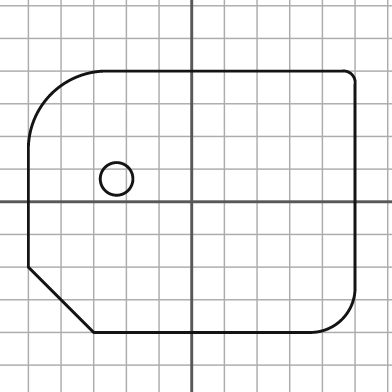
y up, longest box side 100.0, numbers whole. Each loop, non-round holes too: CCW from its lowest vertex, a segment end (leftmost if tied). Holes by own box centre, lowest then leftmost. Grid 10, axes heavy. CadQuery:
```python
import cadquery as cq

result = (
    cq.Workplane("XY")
    .moveTo(-30.0, -40.0)
    .lineTo(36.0, -40.0)
    .threePointArc((46.0, -36.0), (50.0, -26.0))
    .lineTo(50.0, 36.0)
    .threePointArc((49.0, 39.0), (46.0, 40.0))
    .lineTo(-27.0, 40.0)
    .threePointArc((-43.0, 33.0), (-50.0, 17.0))
    .lineTo(-50.0, -20.0)
    .close()
    .moveTo(-23.0, 7.0)
    .circle(5.0)
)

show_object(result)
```